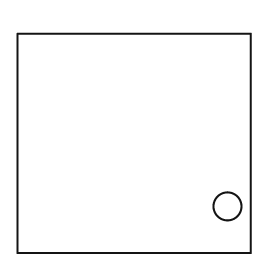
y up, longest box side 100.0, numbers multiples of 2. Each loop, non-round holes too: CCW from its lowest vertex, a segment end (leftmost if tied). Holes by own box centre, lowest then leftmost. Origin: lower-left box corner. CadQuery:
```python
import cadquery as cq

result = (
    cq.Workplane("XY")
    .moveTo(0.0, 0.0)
    .lineTo(100.0, 0.0)
    .lineTo(100.0, 94.0)
    .lineTo(0.0, 94.0)
    .close()
    .moveTo(90.0, 20.0)
    .circle(6.0)
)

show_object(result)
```